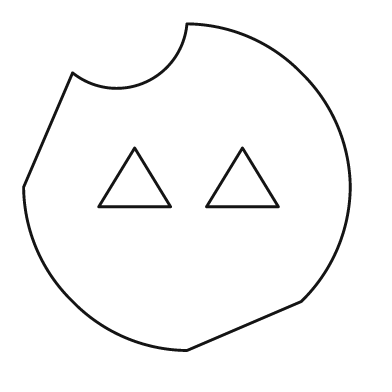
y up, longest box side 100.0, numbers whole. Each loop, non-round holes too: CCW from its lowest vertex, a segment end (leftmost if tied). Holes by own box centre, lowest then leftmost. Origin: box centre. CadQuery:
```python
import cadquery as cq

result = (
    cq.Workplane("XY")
    .moveTo(0.0, -50.0)
    .lineTo(35.0, -35.0)
    .threePointArc((46.0, -19.0), (50.0, 0.0))
    .threePointArc((46.0, 19.0), (35.0, 35.0))
    .threePointArc((19.0, 46.0), (0.0, 50.0))
    .threePointArc((-13.0, 32.0), (-35.0, 35.0))
    .lineTo(-50.0, 0.0)
    .threePointArc((-46.0, -19.0), (-35.0, -35.0))
    .threePointArc((-19.0, -46.0), (0.0, -50.0))
    .close()
    .moveTo(-27.0, -6.0)
    .lineTo(-5.0, -6.0)
    .lineTo(-16.0, 12.0)
    .close()
    .moveTo(6.0, -6.0)
    .lineTo(28.0, -6.0)
    .lineTo(17.0, 12.0)
    .close()
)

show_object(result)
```